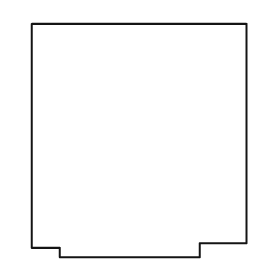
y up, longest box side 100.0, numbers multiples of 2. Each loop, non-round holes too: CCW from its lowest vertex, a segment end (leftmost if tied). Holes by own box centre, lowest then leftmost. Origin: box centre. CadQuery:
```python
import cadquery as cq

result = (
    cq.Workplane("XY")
    .moveTo(-34.0, -50.0)
    .lineTo(26.0, -50.0)
    .lineTo(26.0, -44.0)
    .lineTo(46.0, -44.0)
    .lineTo(46.0, 50.0)
    .lineTo(-46.0, 50.0)
    .lineTo(-46.0, -46.0)
    .lineTo(-34.0, -46.0)
    .close()
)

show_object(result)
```